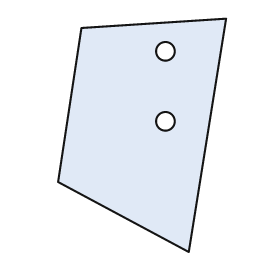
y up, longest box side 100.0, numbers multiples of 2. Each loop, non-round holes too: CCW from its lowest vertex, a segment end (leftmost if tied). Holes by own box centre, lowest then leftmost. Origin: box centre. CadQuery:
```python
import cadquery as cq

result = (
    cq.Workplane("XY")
    .moveTo(20.0, -50.0)
    .lineTo(36.0, 50.0)
    .lineTo(-26.0, 46.0)
    .lineTo(-36.0, -20.0)
    .close()
    .moveTo(10.0, 6.0)
    .circle(4.0)
    .moveTo(10.0, 36.0)
    .circle(4.0)
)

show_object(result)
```